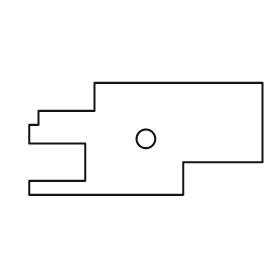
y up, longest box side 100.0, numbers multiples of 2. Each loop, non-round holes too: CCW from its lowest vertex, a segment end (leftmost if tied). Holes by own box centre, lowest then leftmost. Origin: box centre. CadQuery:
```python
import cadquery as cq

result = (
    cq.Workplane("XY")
    .moveTo(-50.0, -24.0)
    .lineTo(16.0, -24.0)
    .lineTo(16.0, -10.0)
    .lineTo(50.0, -10.0)
    .lineTo(50.0, 24.0)
    .lineTo(-22.0, 24.0)
    .lineTo(-22.0, 12.0)
    .lineTo(-46.0, 12.0)
    .lineTo(-46.0, 6.0)
    .lineTo(-50.0, 6.0)
    .lineTo(-50.0, -2.0)
    .lineTo(-26.0, -2.0)
    .lineTo(-26.0, -18.0)
    .lineTo(-50.0, -18.0)
    .close()
    .moveTo(0.0, 0.0)
    .circle(4.0)
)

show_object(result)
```